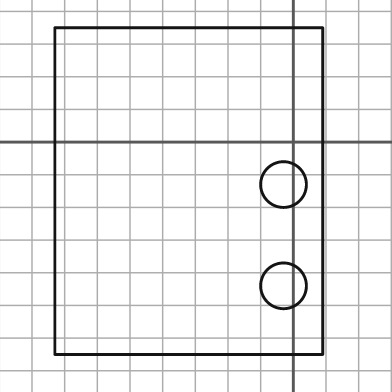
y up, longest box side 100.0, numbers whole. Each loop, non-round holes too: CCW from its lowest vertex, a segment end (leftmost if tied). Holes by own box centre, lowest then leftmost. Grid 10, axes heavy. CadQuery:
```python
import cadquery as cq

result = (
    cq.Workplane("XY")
    .moveTo(-73.0, -65.0)
    .lineTo(9.0, -65.0)
    .lineTo(9.0, 35.0)
    .lineTo(-73.0, 35.0)
    .close()
    .moveTo(-3.0, -44.0)
    .circle(7.0)
    .moveTo(-3.0, -13.0)
    .circle(7.0)
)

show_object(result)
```